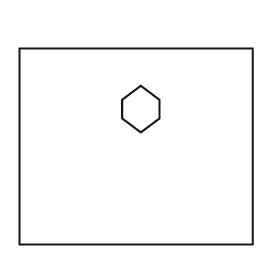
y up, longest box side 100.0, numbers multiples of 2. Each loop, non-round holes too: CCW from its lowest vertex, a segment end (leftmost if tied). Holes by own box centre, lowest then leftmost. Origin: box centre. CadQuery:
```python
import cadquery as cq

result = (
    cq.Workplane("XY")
    .moveTo(-50.0, -42.0)
    .lineTo(50.0, -42.0)
    .lineTo(50.0, 42.0)
    .lineTo(-50.0, 42.0)
    .close()
    .moveTo(2.0, 6.0)
    .lineTo(10.0, 12.0)
    .lineTo(10.0, 20.0)
    .lineTo(2.0, 26.0)
    .lineTo(-6.0, 20.0)
    .lineTo(-6.0, 12.0)
    .close()
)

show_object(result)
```